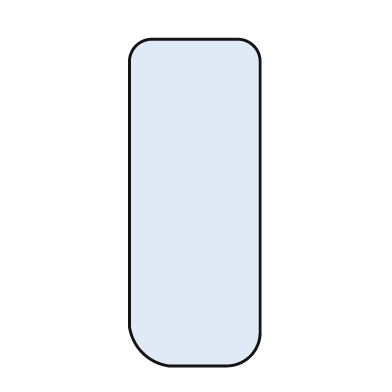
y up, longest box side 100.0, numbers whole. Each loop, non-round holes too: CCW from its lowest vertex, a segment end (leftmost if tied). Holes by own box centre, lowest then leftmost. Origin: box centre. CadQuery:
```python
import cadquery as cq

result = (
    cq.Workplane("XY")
    .moveTo(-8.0, -50.0)
    .lineTo(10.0, -50.0)
    .threePointArc((17.0, -47.0), (20.0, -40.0))
    .lineTo(20.0, 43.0)
    .threePointArc((18.0, 48.0), (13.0, 50.0))
    .lineTo(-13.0, 50.0)
    .threePointArc((-18.0, 48.0), (-20.0, 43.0))
    .lineTo(-20.0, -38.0)
    .threePointArc((-16.0, -46.0), (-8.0, -50.0))
    .close()
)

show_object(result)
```